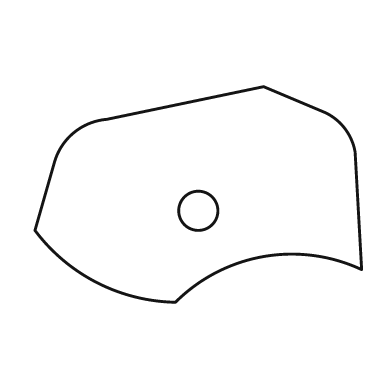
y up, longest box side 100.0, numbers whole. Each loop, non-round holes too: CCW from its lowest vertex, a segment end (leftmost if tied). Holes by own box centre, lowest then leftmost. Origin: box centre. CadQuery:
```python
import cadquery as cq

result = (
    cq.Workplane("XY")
    .moveTo(-7.0, -33.0)
    .threePointArc((20.0, -19.0), (50.0, -23.0))
    .lineTo(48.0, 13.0)
    .threePointArc((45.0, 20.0), (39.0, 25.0))
    .lineTo(20.0, 33.0)
    .lineTo(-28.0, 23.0)
    .threePointArc((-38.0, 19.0), (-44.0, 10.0))
    .lineTo(-50.0, -11.0)
    .threePointArc((-31.0, -27.0), (-7.0, -33.0))
    .close()
    .moveTo(0.0, -5.0)
    .circle(6.0)
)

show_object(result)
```